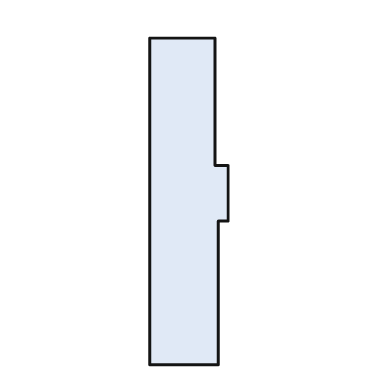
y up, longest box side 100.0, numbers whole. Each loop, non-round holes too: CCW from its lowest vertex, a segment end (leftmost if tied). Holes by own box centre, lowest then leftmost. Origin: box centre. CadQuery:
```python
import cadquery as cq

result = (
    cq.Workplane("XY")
    .moveTo(-12.0, -50.0)
    .lineTo(9.0, -50.0)
    .lineTo(9.0, -6.0)
    .lineTo(12.0, -6.0)
    .lineTo(12.0, 11.0)
    .lineTo(8.0, 11.0)
    .lineTo(8.0, 50.0)
    .lineTo(-12.0, 50.0)
    .close()
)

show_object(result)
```